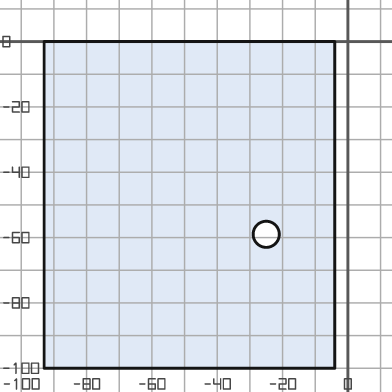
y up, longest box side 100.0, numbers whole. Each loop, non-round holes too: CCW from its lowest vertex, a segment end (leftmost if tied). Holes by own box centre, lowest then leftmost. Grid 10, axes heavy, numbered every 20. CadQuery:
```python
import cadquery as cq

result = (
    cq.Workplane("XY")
    .moveTo(-93.0, -100.0)
    .lineTo(-4.0, -100.0)
    .lineTo(-4.0, 0.0)
    .lineTo(-93.0, 0.0)
    .close()
    .moveTo(-25.0, -59.0)
    .circle(4.0)
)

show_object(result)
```